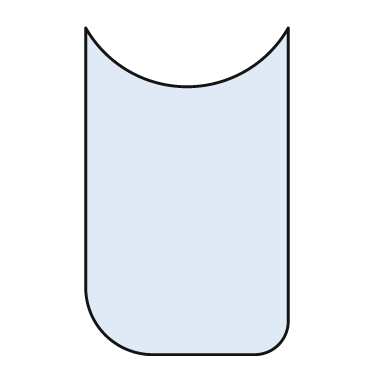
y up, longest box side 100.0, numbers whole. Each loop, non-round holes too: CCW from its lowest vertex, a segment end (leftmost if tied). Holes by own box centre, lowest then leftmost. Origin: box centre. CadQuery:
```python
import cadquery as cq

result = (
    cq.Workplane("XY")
    .moveTo(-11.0, -50.0)
    .lineTo(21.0, -50.0)
    .threePointArc((28.0, -47.0), (31.0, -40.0))
    .lineTo(31.0, 50.0)
    .threePointArc((0.0, 32.0), (-31.0, 50.0))
    .lineTo(-31.0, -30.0)
    .threePointArc((-25.0, -44.0), (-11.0, -50.0))
    .close()
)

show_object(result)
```